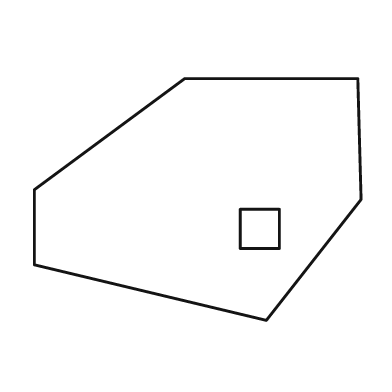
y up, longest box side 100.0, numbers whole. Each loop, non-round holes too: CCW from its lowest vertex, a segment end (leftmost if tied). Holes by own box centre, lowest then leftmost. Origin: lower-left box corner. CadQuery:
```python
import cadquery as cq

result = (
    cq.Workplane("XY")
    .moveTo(71.0, 0.0)
    .lineTo(100.0, 37.0)
    .lineTo(99.0, 74.0)
    .lineTo(46.0, 74.0)
    .lineTo(0.0, 40.0)
    .lineTo(0.0, 17.0)
    .close()
    .moveTo(63.0, 22.0)
    .lineTo(75.0, 22.0)
    .lineTo(75.0, 34.0)
    .lineTo(63.0, 34.0)
    .close()
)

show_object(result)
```